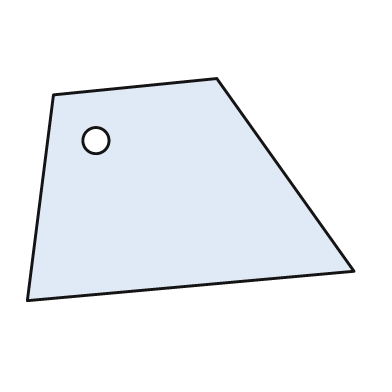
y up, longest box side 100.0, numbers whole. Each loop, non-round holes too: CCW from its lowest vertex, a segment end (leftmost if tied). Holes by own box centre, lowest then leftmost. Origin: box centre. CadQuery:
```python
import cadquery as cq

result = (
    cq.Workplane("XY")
    .moveTo(-50.0, -34.0)
    .lineTo(50.0, -25.0)
    .lineTo(8.0, 34.0)
    .lineTo(-42.0, 29.0)
    .close()
    .moveTo(-29.0, 15.0)
    .circle(4.0)
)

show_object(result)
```